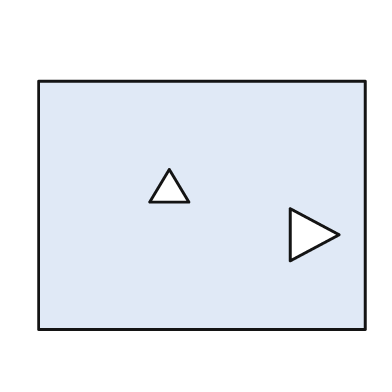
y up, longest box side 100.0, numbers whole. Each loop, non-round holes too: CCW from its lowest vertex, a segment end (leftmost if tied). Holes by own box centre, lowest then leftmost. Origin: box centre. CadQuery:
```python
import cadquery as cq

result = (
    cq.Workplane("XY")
    .moveTo(-50.0, -38.0)
    .lineTo(50.0, -38.0)
    .lineTo(50.0, 38.0)
    .lineTo(-50.0, 38.0)
    .close()
    .moveTo(27.0, -17.0)
    .lineTo(42.0, -9.0)
    .lineTo(27.0, -1.0)
    .close()
    .moveTo(-16.0, 1.0)
    .lineTo(-4.0, 1.0)
    .lineTo(-10.0, 11.0)
    .close()
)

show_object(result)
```